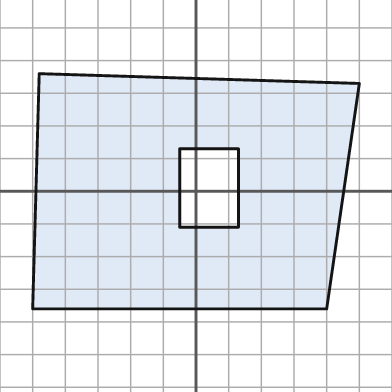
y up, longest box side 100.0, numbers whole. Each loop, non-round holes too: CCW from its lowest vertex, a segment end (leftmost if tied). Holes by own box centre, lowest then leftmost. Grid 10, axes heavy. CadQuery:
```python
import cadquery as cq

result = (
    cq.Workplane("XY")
    .moveTo(-50.0, -36.0)
    .lineTo(40.0, -36.0)
    .lineTo(50.0, 33.0)
    .lineTo(-48.0, 36.0)
    .close()
    .moveTo(-5.0, -11.0)
    .lineTo(13.0, -11.0)
    .lineTo(13.0, 13.0)
    .lineTo(-5.0, 13.0)
    .close()
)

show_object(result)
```